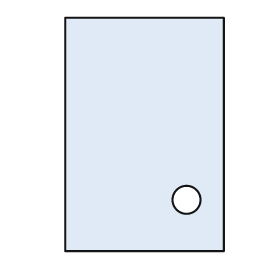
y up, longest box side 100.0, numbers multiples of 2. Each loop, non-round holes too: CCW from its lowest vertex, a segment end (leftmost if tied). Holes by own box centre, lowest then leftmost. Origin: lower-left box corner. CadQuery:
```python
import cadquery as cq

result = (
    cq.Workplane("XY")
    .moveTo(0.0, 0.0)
    .lineTo(68.0, 0.0)
    .lineTo(68.0, 100.0)
    .lineTo(0.0, 100.0)
    .close()
    .moveTo(52.0, 22.0)
    .circle(6.0)
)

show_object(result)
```